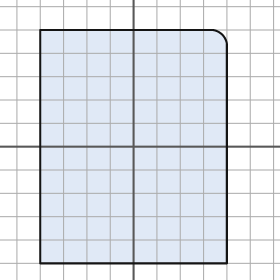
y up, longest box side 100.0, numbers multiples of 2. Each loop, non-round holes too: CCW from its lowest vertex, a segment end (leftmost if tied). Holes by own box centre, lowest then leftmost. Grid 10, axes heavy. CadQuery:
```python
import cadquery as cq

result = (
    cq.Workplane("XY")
    .moveTo(-40.0, -50.0)
    .lineTo(40.0, -50.0)
    .lineTo(40.0, 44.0)
    .threePointArc((38.0, 48.0), (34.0, 50.0))
    .lineTo(-40.0, 50.0)
    .close()
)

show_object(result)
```